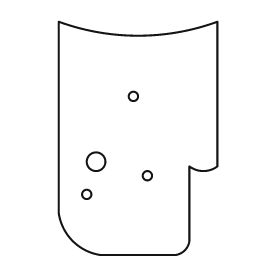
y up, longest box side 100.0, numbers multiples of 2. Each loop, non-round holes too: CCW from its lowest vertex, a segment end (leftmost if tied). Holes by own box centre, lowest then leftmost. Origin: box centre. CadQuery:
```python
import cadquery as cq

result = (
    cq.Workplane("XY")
    .moveTo(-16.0, -50.0)
    .lineTo(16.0, -50.0)
    .threePointArc((20.0, -48.0), (22.0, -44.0))
    .lineTo(22.0, -12.0)
    .threePointArc((28.0, -14.0), (34.0, -12.0))
    .lineTo(34.0, 50.0)
    .threePointArc((0.0, 44.0), (-34.0, 50.0))
    .lineTo(-34.0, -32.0)
    .threePointArc((-28.0, -44.0), (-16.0, -50.0))
    .close()
    .moveTo(-22.0, -24.0)
    .circle(2.0)
    .moveTo(4.0, -16.0)
    .circle(2.0)
    .moveTo(-18.0, -10.0)
    .circle(4.0)
    .moveTo(-2.0, 18.0)
    .circle(2.0)
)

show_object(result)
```